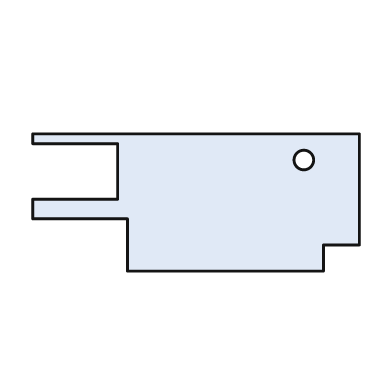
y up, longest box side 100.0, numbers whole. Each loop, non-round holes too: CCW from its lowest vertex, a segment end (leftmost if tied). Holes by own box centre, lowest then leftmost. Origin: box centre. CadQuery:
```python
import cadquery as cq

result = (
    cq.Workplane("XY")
    .moveTo(-21.0, -21.0)
    .lineTo(39.0, -21.0)
    .lineTo(39.0, -13.0)
    .lineTo(50.0, -13.0)
    .lineTo(50.0, 21.0)
    .lineTo(-50.0, 21.0)
    .lineTo(-50.0, 18.0)
    .lineTo(-24.0, 18.0)
    .lineTo(-24.0, 1.0)
    .lineTo(-50.0, 1.0)
    .lineTo(-50.0, -5.0)
    .lineTo(-21.0, -5.0)
    .close()
    .moveTo(33.0, 13.0)
    .circle(3.0)
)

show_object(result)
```